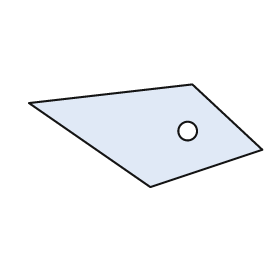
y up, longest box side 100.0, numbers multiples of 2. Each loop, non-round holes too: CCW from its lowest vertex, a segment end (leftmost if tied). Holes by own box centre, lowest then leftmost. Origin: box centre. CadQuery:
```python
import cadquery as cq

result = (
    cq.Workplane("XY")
    .moveTo(2.0, -22.0)
    .lineTo(50.0, -6.0)
    .lineTo(20.0, 22.0)
    .lineTo(-50.0, 14.0)
    .close()
    .moveTo(18.0, 2.0)
    .circle(4.0)
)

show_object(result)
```